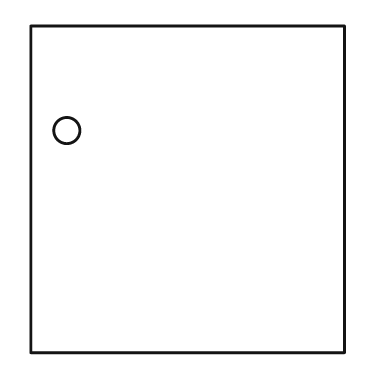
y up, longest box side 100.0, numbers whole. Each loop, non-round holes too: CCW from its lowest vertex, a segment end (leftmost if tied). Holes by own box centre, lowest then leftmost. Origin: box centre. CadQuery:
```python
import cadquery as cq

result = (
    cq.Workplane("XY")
    .moveTo(-48.0, -50.0)
    .lineTo(48.0, -50.0)
    .lineTo(48.0, 50.0)
    .lineTo(-48.0, 50.0)
    .close()
    .moveTo(-37.0, 18.0)
    .circle(4.0)
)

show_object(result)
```